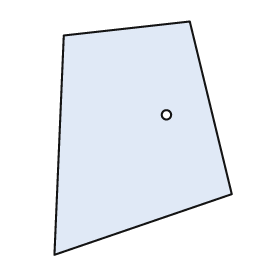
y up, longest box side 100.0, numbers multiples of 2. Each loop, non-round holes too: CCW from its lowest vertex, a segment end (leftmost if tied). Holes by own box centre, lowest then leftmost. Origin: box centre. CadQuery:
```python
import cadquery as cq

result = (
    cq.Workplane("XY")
    .moveTo(-38.0, -50.0)
    .lineTo(38.0, -24.0)
    .lineTo(20.0, 50.0)
    .lineTo(-34.0, 44.0)
    .close()
    .moveTo(10.0, 10.0)
    .circle(2.0)
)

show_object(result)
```